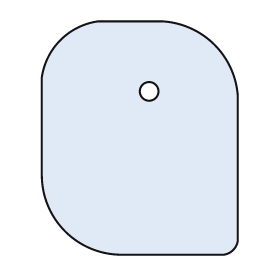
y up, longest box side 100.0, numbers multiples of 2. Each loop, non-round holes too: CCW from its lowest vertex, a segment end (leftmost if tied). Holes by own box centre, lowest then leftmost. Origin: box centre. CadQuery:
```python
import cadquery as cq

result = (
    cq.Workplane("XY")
    .moveTo(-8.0, -50.0)
    .lineTo(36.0, -50.0)
    .threePointArc((40.0, -48.0), (42.0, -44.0))
    .lineTo(42.0, 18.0)
    .threePointArc((32.0, 40.0), (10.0, 50.0))
    .lineTo(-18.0, 50.0)
    .threePointArc((-34.0, 42.0), (-42.0, 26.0))
    .lineTo(-42.0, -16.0)
    .threePointArc((-32.0, -40.0), (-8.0, -50.0))
    .close()
    .moveTo(4.0, 20.0)
    .circle(4.0)
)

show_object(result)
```